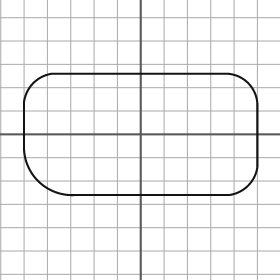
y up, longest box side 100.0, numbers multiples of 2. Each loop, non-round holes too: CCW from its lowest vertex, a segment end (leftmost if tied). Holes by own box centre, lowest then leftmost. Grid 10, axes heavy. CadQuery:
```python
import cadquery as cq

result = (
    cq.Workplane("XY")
    .moveTo(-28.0, -26.0)
    .lineTo(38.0, -26.0)
    .threePointArc((46.0, -22.0), (50.0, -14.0))
    .lineTo(50.0, 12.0)
    .threePointArc((46.0, 22.0), (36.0, 26.0))
    .lineTo(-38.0, 26.0)
    .threePointArc((-46.0, 22.0), (-50.0, 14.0))
    .lineTo(-50.0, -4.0)
    .threePointArc((-44.0, -20.0), (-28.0, -26.0))
    .close()
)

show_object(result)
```